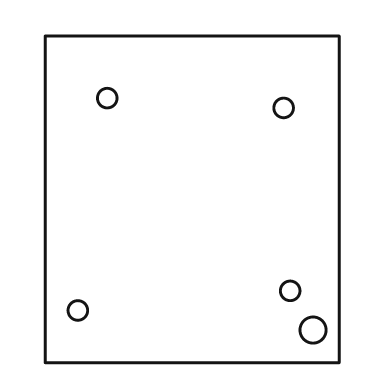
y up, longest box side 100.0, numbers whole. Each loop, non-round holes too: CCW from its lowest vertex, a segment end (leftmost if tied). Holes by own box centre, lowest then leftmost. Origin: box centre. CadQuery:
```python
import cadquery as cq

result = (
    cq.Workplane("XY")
    .moveTo(-45.0, -50.0)
    .lineTo(45.0, -50.0)
    .lineTo(45.0, 50.0)
    .lineTo(-45.0, 50.0)
    .close()
    .moveTo(37.0, -40.0)
    .circle(4.0)
    .moveTo(-35.0, -34.0)
    .circle(3.0)
    .moveTo(30.0, -28.0)
    .circle(3.0)
    .moveTo(28.0, 28.0)
    .circle(3.0)
    .moveTo(-26.0, 31.0)
    .circle(3.0)
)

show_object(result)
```